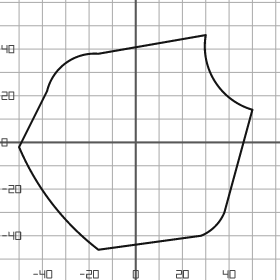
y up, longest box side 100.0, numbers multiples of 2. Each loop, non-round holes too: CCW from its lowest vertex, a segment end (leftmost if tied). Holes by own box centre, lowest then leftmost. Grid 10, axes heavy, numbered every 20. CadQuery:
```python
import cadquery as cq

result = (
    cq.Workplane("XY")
    .moveTo(-16.0, -46.0)
    .lineTo(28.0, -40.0)
    .threePointArc((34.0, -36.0), (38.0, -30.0))
    .lineTo(50.0, 14.0)
    .threePointArc((34.0, 26.0), (30.0, 46.0))
    .lineTo(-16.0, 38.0)
    .threePointArc((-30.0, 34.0), (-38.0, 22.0))
    .lineTo(-50.0, -2.0)
    .threePointArc((-36.0, -26.0), (-16.0, -46.0))
    .close()
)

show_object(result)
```